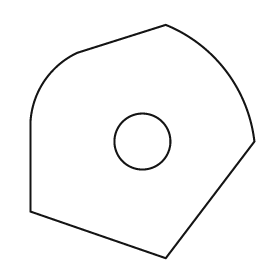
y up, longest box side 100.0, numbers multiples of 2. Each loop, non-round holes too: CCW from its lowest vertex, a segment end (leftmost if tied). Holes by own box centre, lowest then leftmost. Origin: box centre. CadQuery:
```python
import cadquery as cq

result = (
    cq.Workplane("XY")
    .moveTo(10.0, -50.0)
    .lineTo(48.0, 0.0)
    .threePointArc((36.0, 30.0), (10.0, 50.0))
    .lineTo(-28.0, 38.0)
    .threePointArc((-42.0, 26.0), (-48.0, 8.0))
    .lineTo(-48.0, -30.0)
    .close()
    .moveTo(0.0, 0.0)
    .circle(12.0)
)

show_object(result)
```